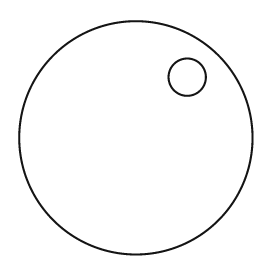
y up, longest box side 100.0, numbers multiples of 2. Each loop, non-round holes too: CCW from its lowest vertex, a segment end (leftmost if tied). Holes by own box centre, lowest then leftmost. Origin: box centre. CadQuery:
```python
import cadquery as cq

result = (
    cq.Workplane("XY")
    .moveTo(0.0, 0.0)
    .circle(50.0)
    .moveTo(22.0, 26.0)
    .circle(8.0)
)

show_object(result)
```